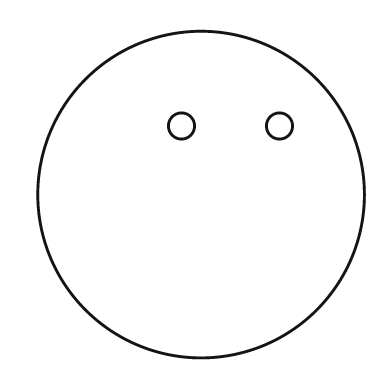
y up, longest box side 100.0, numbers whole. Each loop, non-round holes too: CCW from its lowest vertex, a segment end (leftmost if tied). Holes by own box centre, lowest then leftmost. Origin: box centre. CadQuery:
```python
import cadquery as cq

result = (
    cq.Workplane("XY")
    .moveTo(0.0, 0.0)
    .circle(50.0)
    .moveTo(-6.0, 21.0)
    .circle(4.0)
    .moveTo(24.0, 21.0)
    .circle(4.0)
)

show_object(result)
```